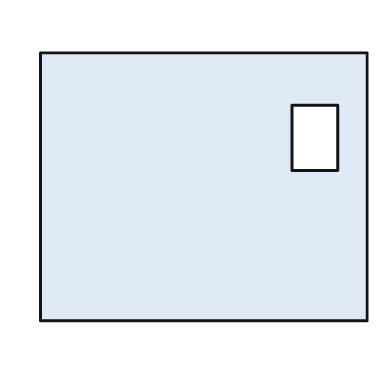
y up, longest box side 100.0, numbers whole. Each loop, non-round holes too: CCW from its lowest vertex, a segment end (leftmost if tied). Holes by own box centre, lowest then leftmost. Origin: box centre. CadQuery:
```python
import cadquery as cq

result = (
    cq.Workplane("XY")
    .moveTo(-50.0, -41.0)
    .lineTo(50.0, -41.0)
    .lineTo(50.0, 41.0)
    .lineTo(-50.0, 41.0)
    .close()
    .moveTo(27.0, 5.0)
    .lineTo(41.0, 5.0)
    .lineTo(41.0, 25.0)
    .lineTo(27.0, 25.0)
    .close()
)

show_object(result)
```